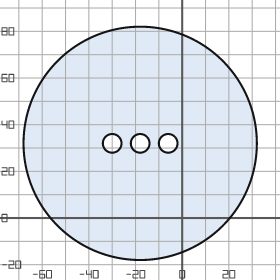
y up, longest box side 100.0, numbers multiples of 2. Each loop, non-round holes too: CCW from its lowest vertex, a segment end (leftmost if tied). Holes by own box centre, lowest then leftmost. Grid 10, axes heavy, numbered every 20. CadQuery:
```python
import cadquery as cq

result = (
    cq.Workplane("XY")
    .moveTo(-18.0, 32.0)
    .circle(50.0)
    .moveTo(-30.0, 32.0)
    .circle(4.0)
    .moveTo(-18.0, 32.0)
    .circle(4.0)
    .moveTo(-6.0, 32.0)
    .circle(4.0)
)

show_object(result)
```